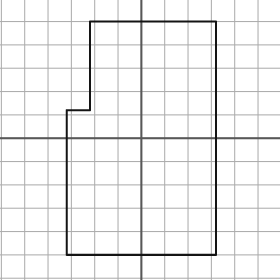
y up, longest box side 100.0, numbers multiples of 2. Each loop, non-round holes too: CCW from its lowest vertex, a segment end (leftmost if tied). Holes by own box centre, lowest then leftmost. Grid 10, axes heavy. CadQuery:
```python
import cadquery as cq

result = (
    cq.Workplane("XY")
    .moveTo(-32.0, -50.0)
    .lineTo(32.0, -50.0)
    .lineTo(32.0, 50.0)
    .lineTo(-22.0, 50.0)
    .lineTo(-22.0, 12.0)
    .lineTo(-32.0, 12.0)
    .close()
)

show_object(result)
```